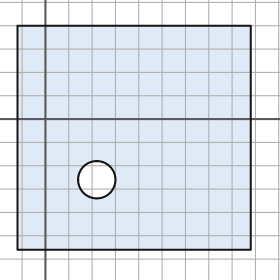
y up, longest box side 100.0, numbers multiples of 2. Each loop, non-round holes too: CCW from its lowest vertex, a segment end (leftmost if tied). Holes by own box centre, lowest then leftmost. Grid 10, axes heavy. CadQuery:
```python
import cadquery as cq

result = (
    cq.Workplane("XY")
    .moveTo(-12.0, -56.0)
    .lineTo(88.0, -56.0)
    .lineTo(88.0, 40.0)
    .lineTo(-12.0, 40.0)
    .close()
    .moveTo(22.0, -26.0)
    .circle(8.0)
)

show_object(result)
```